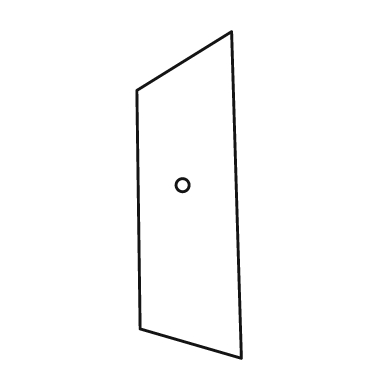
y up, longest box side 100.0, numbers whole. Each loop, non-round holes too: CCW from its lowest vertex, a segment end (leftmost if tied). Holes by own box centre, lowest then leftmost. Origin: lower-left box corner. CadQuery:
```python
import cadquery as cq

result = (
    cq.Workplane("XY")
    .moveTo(32.0, 0.0)
    .lineTo(29.0, 100.0)
    .lineTo(0.0, 82.0)
    .lineTo(1.0, 9.0)
    .close()
    .moveTo(14.0, 53.0)
    .circle(2.0)
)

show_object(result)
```